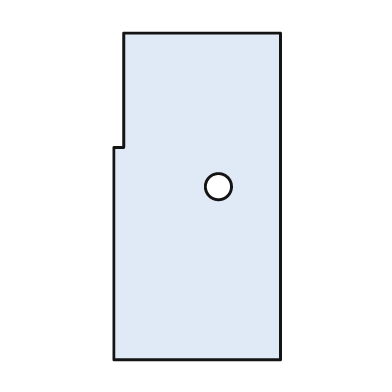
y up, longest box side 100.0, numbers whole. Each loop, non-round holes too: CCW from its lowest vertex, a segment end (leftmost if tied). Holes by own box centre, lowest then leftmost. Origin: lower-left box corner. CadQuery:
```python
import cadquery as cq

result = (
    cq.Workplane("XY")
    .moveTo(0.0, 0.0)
    .lineTo(51.0, 0.0)
    .lineTo(51.0, 100.0)
    .lineTo(3.0, 100.0)
    .lineTo(3.0, 65.0)
    .lineTo(0.0, 65.0)
    .close()
    .moveTo(32.0, 53.0)
    .circle(4.0)
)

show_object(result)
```